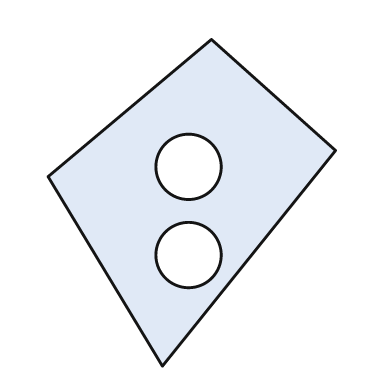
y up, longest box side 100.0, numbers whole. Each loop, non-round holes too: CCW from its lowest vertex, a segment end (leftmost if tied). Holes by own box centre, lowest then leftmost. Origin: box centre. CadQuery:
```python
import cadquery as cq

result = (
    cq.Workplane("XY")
    .moveTo(-9.0, -50.0)
    .lineTo(44.0, 16.0)
    .lineTo(6.0, 50.0)
    .lineTo(-44.0, 8.0)
    .close()
    .moveTo(-1.0, -16.0)
    .circle(10.0)
    .moveTo(-1.0, 11.0)
    .circle(10.0)
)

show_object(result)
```